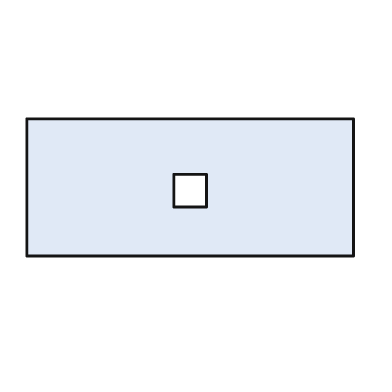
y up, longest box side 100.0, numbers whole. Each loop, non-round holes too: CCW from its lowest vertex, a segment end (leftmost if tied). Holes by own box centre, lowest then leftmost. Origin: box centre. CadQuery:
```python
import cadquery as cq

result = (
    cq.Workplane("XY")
    .moveTo(-50.0, -21.0)
    .lineTo(50.0, -21.0)
    .lineTo(50.0, 21.0)
    .lineTo(-50.0, 21.0)
    .close()
    .moveTo(-5.0, -6.0)
    .lineTo(5.0, -6.0)
    .lineTo(5.0, 4.0)
    .lineTo(-5.0, 4.0)
    .close()
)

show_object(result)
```